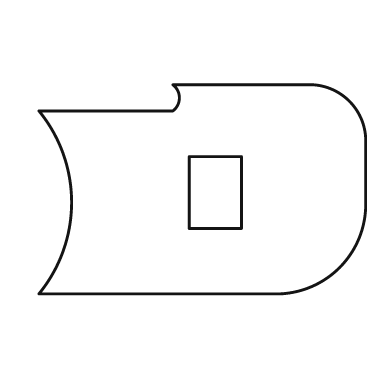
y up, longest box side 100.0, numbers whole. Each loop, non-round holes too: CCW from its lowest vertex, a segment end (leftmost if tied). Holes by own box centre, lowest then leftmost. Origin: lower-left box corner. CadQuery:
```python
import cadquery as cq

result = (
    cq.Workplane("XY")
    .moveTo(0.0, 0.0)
    .lineTo(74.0, 0.0)
    .threePointArc((92.0, 8.0), (100.0, 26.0))
    .lineTo(100.0, 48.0)
    .threePointArc((95.0, 59.0), (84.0, 64.0))
    .lineTo(41.0, 64.0)
    .threePointArc((43.0, 60.0), (41.0, 56.0))
    .lineTo(0.0, 56.0)
    .threePointArc((10.0, 28.0), (0.0, 0.0))
    .close()
    .moveTo(46.0, 20.0)
    .lineTo(62.0, 20.0)
    .lineTo(62.0, 42.0)
    .lineTo(46.0, 42.0)
    .close()
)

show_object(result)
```